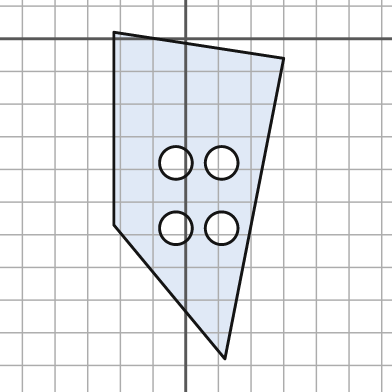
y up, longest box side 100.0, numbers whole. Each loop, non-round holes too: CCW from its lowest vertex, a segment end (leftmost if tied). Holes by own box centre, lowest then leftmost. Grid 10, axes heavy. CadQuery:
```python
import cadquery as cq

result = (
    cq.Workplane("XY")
    .moveTo(12.0, -98.0)
    .lineTo(30.0, -6.0)
    .lineTo(-22.0, 2.0)
    .lineTo(-22.0, -57.0)
    .close()
    .moveTo(-3.0, -58.0)
    .circle(5.0)
    .moveTo(11.0, -58.0)
    .circle(5.0)
    .moveTo(-3.0, -38.0)
    .circle(5.0)
    .moveTo(11.0, -38.0)
    .circle(5.0)
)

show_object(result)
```